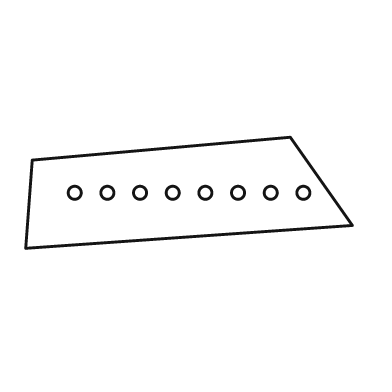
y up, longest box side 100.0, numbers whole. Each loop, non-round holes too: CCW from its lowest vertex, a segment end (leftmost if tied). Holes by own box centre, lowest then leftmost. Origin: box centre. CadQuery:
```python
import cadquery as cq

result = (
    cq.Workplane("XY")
    .moveTo(-50.0, -17.0)
    .lineTo(50.0, -10.0)
    .lineTo(31.0, 17.0)
    .lineTo(-48.0, 10.0)
    .close()
    .moveTo(-35.0, 0.0)
    .circle(2.0)
    .moveTo(-25.0, 0.0)
    .circle(2.0)
    .moveTo(-15.0, 0.0)
    .circle(2.0)
    .moveTo(-5.0, 0.0)
    .circle(2.0)
    .moveTo(5.0, 0.0)
    .circle(2.0)
    .moveTo(15.0, 0.0)
    .circle(2.0)
    .moveTo(25.0, 0.0)
    .circle(2.0)
    .moveTo(35.0, 0.0)
    .circle(2.0)
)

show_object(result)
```